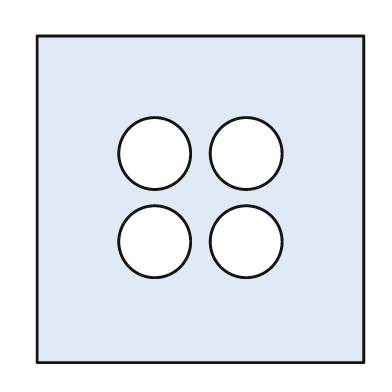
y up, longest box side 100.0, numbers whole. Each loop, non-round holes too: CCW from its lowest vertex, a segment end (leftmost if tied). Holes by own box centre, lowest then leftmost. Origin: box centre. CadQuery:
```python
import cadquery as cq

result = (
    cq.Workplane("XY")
    .moveTo(-50.0, -50.0)
    .lineTo(50.0, -50.0)
    .lineTo(50.0, 50.0)
    .lineTo(-50.0, 50.0)
    .close()
    .moveTo(-14.0, -13.0)
    .circle(11.0)
    .moveTo(14.0, -13.0)
    .circle(11.0)
    .moveTo(-14.0, 14.0)
    .circle(11.0)
    .moveTo(14.0, 14.0)
    .circle(11.0)
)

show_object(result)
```